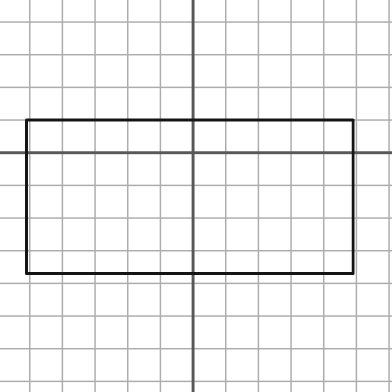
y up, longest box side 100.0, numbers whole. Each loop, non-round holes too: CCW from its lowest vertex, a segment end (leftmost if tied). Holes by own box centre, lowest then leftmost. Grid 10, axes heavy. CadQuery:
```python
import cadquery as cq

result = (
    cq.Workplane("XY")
    .moveTo(-51.0, -37.0)
    .lineTo(49.0, -37.0)
    .lineTo(49.0, 10.0)
    .lineTo(-51.0, 10.0)
    .close()
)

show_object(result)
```